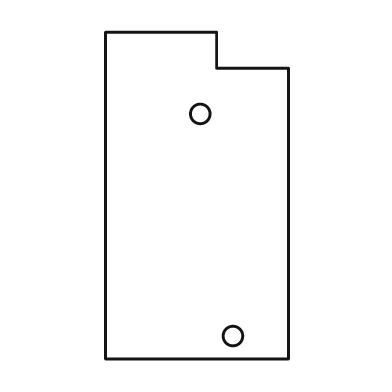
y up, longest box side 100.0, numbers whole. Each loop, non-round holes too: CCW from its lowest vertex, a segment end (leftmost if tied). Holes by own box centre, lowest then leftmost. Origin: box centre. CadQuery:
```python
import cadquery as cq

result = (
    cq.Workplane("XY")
    .moveTo(-28.0, -50.0)
    .lineTo(28.0, -50.0)
    .lineTo(28.0, 39.0)
    .lineTo(6.0, 39.0)
    .lineTo(6.0, 50.0)
    .lineTo(-28.0, 50.0)
    .close()
    .moveTo(11.0, -43.0)
    .circle(3.0)
    .moveTo(1.0, 25.0)
    .circle(3.0)
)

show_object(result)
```